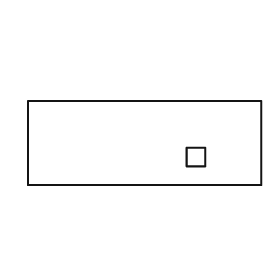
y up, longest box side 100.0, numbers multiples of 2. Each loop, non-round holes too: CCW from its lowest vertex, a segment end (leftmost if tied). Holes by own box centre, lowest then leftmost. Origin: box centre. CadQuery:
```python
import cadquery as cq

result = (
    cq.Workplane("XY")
    .moveTo(-50.0, -18.0)
    .lineTo(50.0, -18.0)
    .lineTo(50.0, 18.0)
    .lineTo(-50.0, 18.0)
    .close()
    .moveTo(18.0, -10.0)
    .lineTo(26.0, -10.0)
    .lineTo(26.0, -2.0)
    .lineTo(18.0, -2.0)
    .close()
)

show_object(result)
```